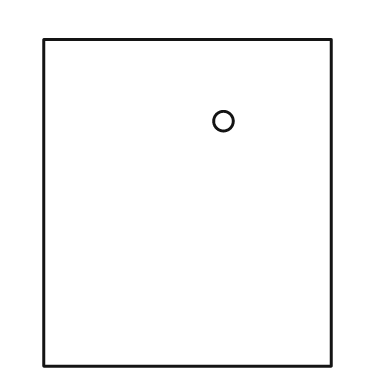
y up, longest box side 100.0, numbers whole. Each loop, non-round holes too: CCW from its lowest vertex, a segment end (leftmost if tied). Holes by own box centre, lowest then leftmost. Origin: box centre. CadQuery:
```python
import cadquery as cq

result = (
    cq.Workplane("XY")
    .moveTo(-44.0, -50.0)
    .lineTo(44.0, -50.0)
    .lineTo(44.0, 50.0)
    .lineTo(-44.0, 50.0)
    .close()
    .moveTo(11.0, 25.0)
    .circle(3.0)
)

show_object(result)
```